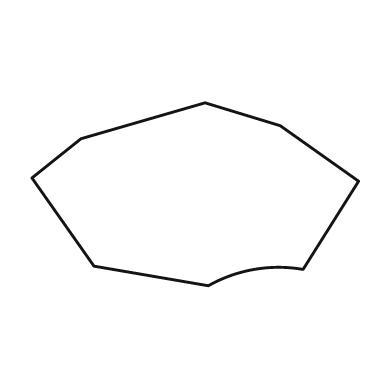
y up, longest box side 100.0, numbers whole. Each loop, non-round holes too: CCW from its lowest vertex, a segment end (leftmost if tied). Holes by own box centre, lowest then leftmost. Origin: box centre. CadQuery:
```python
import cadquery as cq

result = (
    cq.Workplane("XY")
    .moveTo(4.0, -28.0)
    .threePointArc((18.0, -23.0), (33.0, -23.0))
    .lineTo(50.0, 4.0)
    .lineTo(26.0, 21.0)
    .lineTo(3.0, 28.0)
    .lineTo(-35.0, 17.0)
    .lineTo(-50.0, 5.0)
    .lineTo(-31.0, -22.0)
    .close()
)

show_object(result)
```